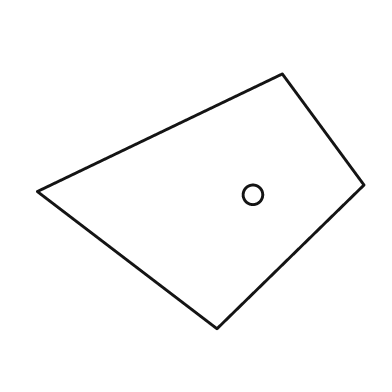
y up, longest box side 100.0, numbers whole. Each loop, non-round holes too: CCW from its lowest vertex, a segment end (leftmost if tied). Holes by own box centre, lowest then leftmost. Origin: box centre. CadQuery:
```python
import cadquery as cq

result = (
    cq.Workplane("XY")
    .moveTo(5.0, -39.0)
    .lineTo(50.0, 5.0)
    .lineTo(25.0, 39.0)
    .lineTo(-50.0, 3.0)
    .close()
    .moveTo(16.0, 2.0)
    .circle(3.0)
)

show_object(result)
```